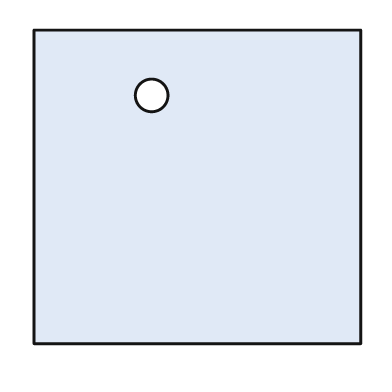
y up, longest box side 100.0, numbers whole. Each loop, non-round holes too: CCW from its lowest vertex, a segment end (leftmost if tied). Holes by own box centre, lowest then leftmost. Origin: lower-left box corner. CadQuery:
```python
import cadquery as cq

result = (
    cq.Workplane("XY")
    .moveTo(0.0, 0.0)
    .lineTo(100.0, 0.0)
    .lineTo(100.0, 96.0)
    .lineTo(0.0, 96.0)
    .close()
    .moveTo(36.0, 76.0)
    .circle(5.0)
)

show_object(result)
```